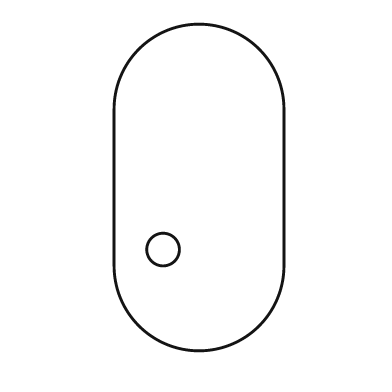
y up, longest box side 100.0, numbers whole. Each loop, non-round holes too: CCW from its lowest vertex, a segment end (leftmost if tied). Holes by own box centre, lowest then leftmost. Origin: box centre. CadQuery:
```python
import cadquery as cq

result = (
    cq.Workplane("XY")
    .moveTo(-26.0, -24.0)
    .threePointArc((0.0, -50.0), (26.0, -24.0))
    .lineTo(26.0, 24.0)
    .threePointArc((0.0, 50.0), (-26.0, 24.0))
    .close()
    .moveTo(-11.0, -19.0)
    .circle(5.0)
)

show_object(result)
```